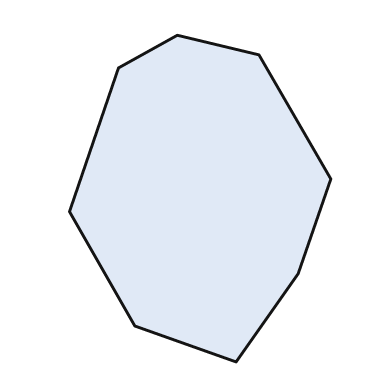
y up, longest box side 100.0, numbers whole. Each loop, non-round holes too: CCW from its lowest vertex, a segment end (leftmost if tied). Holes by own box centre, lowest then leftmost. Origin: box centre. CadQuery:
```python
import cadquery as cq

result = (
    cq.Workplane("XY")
    .moveTo(11.0, -50.0)
    .lineTo(30.0, -23.0)
    .lineTo(40.0, 6.0)
    .lineTo(18.0, 44.0)
    .lineTo(-7.0, 50.0)
    .lineTo(-25.0, 40.0)
    .lineTo(-40.0, -4.0)
    .lineTo(-20.0, -39.0)
    .close()
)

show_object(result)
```